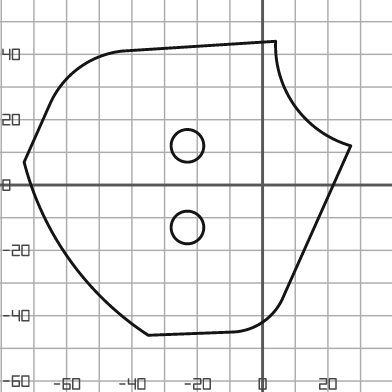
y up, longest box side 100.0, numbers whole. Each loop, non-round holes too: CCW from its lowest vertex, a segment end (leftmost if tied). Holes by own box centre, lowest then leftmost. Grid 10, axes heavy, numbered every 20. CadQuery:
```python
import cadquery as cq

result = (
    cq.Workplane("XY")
    .moveTo(-35.0, -46.0)
    .lineTo(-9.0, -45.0)
    .threePointArc((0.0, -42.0), (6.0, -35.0))
    .lineTo(27.0, 12.0)
    .threePointArc((10.0, 24.0), (4.0, 44.0))
    .lineTo(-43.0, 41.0)
    .threePointArc((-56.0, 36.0), (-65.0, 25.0))
    .lineTo(-73.0, 7.0)
    .threePointArc((-59.0, -23.0), (-35.0, -46.0))
    .close()
    .moveTo(-23.0, -13.0)
    .circle(5.0)
    .moveTo(-23.0, 12.0)
    .circle(5.0)
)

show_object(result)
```